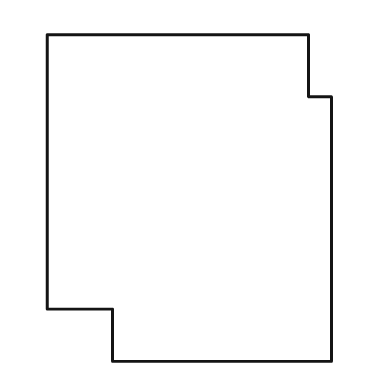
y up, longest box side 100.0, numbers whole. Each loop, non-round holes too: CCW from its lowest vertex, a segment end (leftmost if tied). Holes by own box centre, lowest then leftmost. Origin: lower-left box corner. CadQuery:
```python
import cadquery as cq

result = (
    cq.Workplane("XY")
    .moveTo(20.0, 0.0)
    .lineTo(87.0, 0.0)
    .lineTo(87.0, 81.0)
    .lineTo(80.0, 81.0)
    .lineTo(80.0, 100.0)
    .lineTo(0.0, 100.0)
    .lineTo(0.0, 16.0)
    .lineTo(20.0, 16.0)
    .close()
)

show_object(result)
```